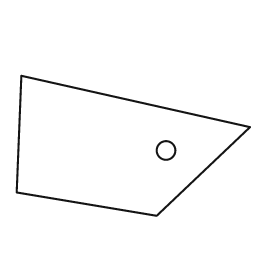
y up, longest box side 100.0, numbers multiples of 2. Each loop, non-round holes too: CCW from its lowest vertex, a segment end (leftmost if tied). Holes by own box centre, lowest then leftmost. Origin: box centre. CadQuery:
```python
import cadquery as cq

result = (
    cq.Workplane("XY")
    .moveTo(10.0, -30.0)
    .lineTo(50.0, 8.0)
    .lineTo(-48.0, 30.0)
    .lineTo(-50.0, -20.0)
    .close()
    .moveTo(14.0, -2.0)
    .circle(4.0)
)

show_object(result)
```